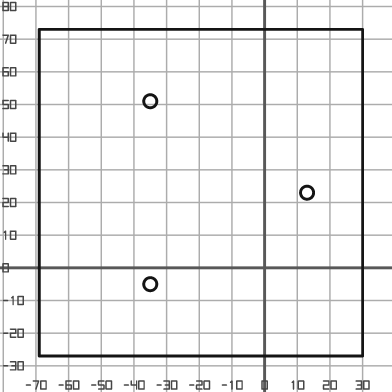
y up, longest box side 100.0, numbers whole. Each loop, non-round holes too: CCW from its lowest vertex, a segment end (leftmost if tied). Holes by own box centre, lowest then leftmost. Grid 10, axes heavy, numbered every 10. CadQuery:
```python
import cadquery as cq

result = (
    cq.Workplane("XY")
    .moveTo(-69.0, -27.0)
    .lineTo(30.0, -27.0)
    .lineTo(30.0, 73.0)
    .lineTo(-69.0, 73.0)
    .close()
    .moveTo(-35.0, -5.0)
    .circle(2.0)
    .moveTo(13.0, 23.0)
    .circle(2.0)
    .moveTo(-35.0, 51.0)
    .circle(2.0)
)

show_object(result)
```